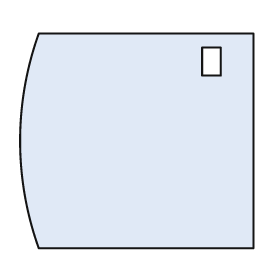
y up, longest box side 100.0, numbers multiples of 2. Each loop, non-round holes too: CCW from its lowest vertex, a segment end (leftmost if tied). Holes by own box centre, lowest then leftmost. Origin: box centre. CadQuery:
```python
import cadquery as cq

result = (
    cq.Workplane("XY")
    .moveTo(-42.0, -46.0)
    .lineTo(50.0, -46.0)
    .lineTo(50.0, 46.0)
    .lineTo(-42.0, 46.0)
    .threePointArc((-50.0, 0.0), (-42.0, -46.0))
    .close()
    .moveTo(28.0, 28.0)
    .lineTo(36.0, 28.0)
    .lineTo(36.0, 40.0)
    .lineTo(28.0, 40.0)
    .close()
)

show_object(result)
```